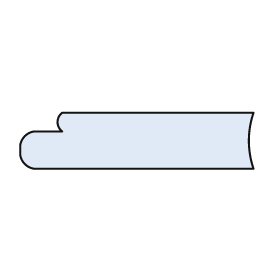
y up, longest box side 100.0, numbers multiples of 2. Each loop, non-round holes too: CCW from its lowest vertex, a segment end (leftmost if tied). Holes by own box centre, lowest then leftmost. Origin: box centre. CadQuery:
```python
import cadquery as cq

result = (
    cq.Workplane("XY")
    .moveTo(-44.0, -12.0)
    .lineTo(50.0, -12.0)
    .threePointArc((48.0, 0.0), (50.0, 12.0))
    .lineTo(-32.0, 12.0)
    .threePointArc((-34.0, 8.0), (-32.0, 4.0))
    .lineTo(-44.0, 4.0)
    .threePointArc((-48.0, 2.0), (-50.0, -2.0))
    .lineTo(-50.0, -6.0)
    .threePointArc((-48.0, -10.0), (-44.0, -12.0))
    .close()
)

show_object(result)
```